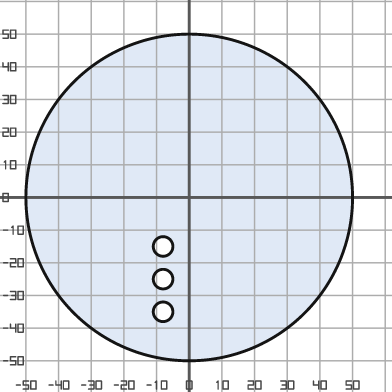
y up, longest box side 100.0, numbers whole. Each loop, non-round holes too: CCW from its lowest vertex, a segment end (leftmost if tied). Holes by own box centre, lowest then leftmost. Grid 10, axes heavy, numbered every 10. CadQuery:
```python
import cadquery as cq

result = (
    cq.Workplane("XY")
    .moveTo(0.0, 0.0)
    .circle(50.0)
    .moveTo(-8.0, -35.0)
    .circle(3.0)
    .moveTo(-8.0, -25.0)
    .circle(3.0)
    .moveTo(-8.0, -15.0)
    .circle(3.0)
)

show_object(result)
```